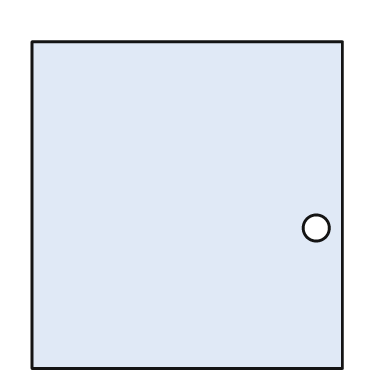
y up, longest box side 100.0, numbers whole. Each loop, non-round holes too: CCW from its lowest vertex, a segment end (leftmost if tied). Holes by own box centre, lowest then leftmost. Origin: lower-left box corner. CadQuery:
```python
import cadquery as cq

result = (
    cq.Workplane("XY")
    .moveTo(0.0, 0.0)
    .lineTo(95.0, 0.0)
    .lineTo(95.0, 100.0)
    .lineTo(0.0, 100.0)
    .close()
    .moveTo(87.0, 43.0)
    .circle(4.0)
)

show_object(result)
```